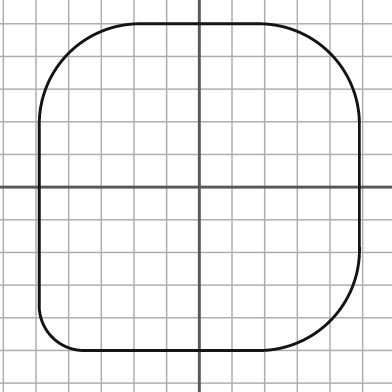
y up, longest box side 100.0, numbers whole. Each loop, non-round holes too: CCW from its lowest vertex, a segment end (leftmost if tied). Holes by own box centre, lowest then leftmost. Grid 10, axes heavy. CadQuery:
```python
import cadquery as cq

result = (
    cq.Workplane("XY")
    .moveTo(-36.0, -50.0)
    .lineTo(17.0, -50.0)
    .threePointArc((40.0, -41.0), (49.0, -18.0))
    .lineTo(49.0, 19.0)
    .threePointArc((40.0, 41.0), (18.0, 50.0))
    .lineTo(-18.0, 50.0)
    .threePointArc((-40.0, 41.0), (-49.0, 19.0))
    .lineTo(-49.0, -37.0)
    .threePointArc((-45.0, -46.0), (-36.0, -50.0))
    .close()
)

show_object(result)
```